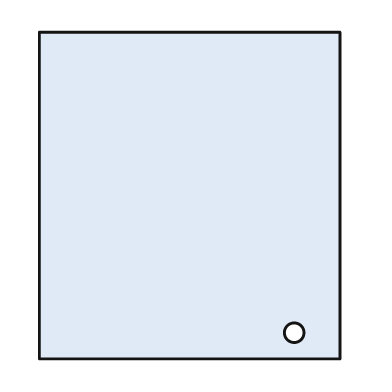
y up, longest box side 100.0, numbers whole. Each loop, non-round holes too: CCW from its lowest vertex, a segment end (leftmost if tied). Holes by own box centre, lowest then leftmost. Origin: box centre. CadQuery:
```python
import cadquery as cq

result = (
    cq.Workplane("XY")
    .moveTo(-46.0, -50.0)
    .lineTo(46.0, -50.0)
    .lineTo(46.0, 50.0)
    .lineTo(-46.0, 50.0)
    .close()
    .moveTo(32.0, -42.0)
    .circle(3.0)
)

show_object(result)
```